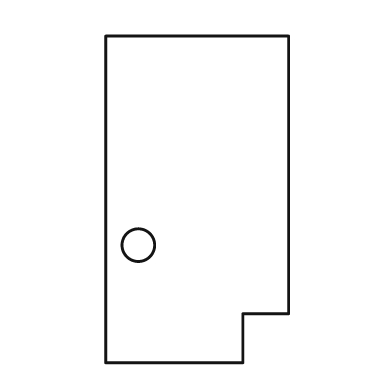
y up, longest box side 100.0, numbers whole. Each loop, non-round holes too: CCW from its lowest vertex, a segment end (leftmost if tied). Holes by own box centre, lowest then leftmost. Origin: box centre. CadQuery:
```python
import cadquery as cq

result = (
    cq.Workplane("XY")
    .moveTo(-28.0, -50.0)
    .lineTo(14.0, -50.0)
    .lineTo(14.0, -35.0)
    .lineTo(28.0, -35.0)
    .lineTo(28.0, 50.0)
    .lineTo(-28.0, 50.0)
    .close()
    .moveTo(-18.0, -14.0)
    .circle(5.0)
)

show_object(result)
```